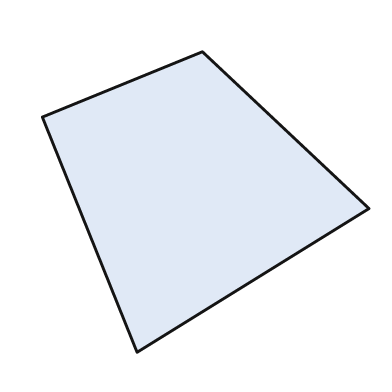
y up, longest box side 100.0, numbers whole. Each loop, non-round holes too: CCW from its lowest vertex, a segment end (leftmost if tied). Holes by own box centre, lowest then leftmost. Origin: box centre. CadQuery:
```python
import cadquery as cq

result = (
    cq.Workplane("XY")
    .moveTo(-21.0, -46.0)
    .lineTo(50.0, -2.0)
    .lineTo(-1.0, 46.0)
    .lineTo(-50.0, 26.0)
    .close()
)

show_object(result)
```